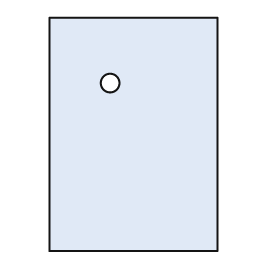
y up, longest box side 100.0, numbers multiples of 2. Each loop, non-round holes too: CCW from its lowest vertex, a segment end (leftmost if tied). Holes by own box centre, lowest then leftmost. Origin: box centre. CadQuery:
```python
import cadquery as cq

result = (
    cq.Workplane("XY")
    .moveTo(-36.0, -50.0)
    .lineTo(36.0, -50.0)
    .lineTo(36.0, 50.0)
    .lineTo(-36.0, 50.0)
    .close()
    .moveTo(-10.0, 22.0)
    .circle(4.0)
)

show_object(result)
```